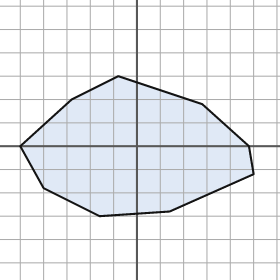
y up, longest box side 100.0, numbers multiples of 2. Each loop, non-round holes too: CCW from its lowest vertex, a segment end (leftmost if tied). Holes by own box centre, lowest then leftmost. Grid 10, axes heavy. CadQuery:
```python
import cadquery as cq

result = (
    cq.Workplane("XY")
    .moveTo(-16.0, -30.0)
    .lineTo(14.0, -28.0)
    .lineTo(50.0, -12.0)
    .lineTo(48.0, 0.0)
    .lineTo(28.0, 18.0)
    .lineTo(-8.0, 30.0)
    .lineTo(-28.0, 20.0)
    .lineTo(-50.0, 0.0)
    .lineTo(-40.0, -18.0)
    .close()
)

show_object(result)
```